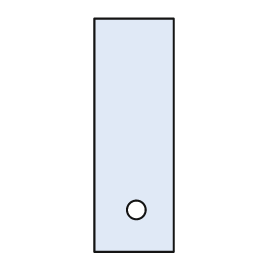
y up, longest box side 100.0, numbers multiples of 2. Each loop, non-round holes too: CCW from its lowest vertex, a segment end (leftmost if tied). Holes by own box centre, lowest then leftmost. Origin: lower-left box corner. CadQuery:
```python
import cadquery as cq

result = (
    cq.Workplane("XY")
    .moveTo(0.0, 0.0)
    .lineTo(34.0, 0.0)
    .lineTo(34.0, 100.0)
    .lineTo(0.0, 100.0)
    .close()
    .moveTo(18.0, 18.0)
    .circle(4.0)
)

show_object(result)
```